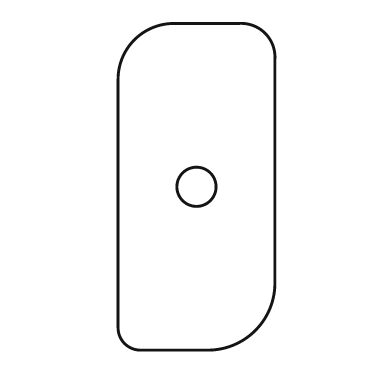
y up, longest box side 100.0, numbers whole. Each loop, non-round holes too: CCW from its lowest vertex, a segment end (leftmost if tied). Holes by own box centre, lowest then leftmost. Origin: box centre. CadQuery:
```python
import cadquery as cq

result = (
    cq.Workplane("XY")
    .moveTo(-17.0, -50.0)
    .lineTo(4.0, -50.0)
    .threePointArc((18.0, -44.0), (24.0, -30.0))
    .lineTo(24.0, 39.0)
    .threePointArc((21.0, 47.0), (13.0, 50.0))
    .lineTo(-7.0, 50.0)
    .threePointArc((-19.0, 45.0), (-24.0, 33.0))
    .lineTo(-24.0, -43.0)
    .threePointArc((-22.0, -48.0), (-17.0, -50.0))
    .close()
    .moveTo(0.0, 0.0)
    .circle(6.0)
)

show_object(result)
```